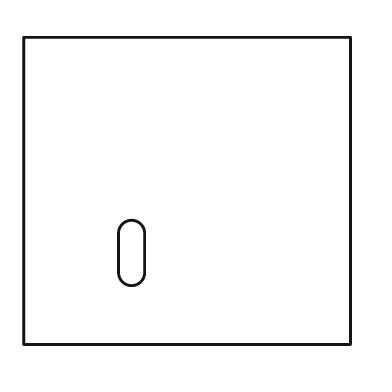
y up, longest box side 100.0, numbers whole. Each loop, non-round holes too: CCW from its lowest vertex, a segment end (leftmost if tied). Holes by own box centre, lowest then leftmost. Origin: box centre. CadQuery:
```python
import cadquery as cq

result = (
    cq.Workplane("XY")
    .moveTo(-50.0, -47.0)
    .lineTo(50.0, -47.0)
    .lineTo(50.0, 47.0)
    .lineTo(-50.0, 47.0)
    .close()
    .moveTo(-21.0, -25.0)
    .threePointArc((-17.0, -29.0), (-13.0, -25.0))
    .lineTo(-13.0, -13.0)
    .threePointArc((-17.0, -9.0), (-21.0, -13.0))
    .close()
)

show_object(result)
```